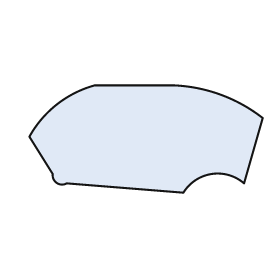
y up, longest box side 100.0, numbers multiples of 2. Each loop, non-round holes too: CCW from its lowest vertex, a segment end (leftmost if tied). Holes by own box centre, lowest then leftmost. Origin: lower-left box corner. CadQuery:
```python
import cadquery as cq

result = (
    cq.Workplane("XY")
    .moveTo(66.0, 0.0)
    .threePointArc((78.0, 8.0), (92.0, 4.0))
    .lineTo(100.0, 32.0)
    .threePointArc((82.0, 42.0), (62.0, 46.0))
    .lineTo(28.0, 46.0)
    .threePointArc((12.0, 38.0), (0.0, 24.0))
    .lineTo(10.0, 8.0)
    .threePointArc((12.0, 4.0), (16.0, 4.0))
    .close()
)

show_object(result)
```